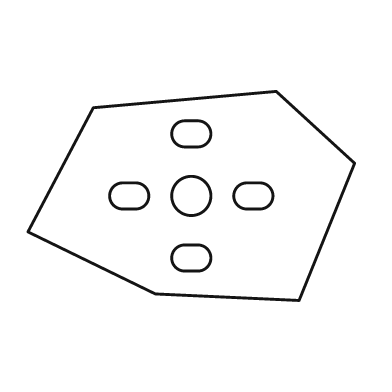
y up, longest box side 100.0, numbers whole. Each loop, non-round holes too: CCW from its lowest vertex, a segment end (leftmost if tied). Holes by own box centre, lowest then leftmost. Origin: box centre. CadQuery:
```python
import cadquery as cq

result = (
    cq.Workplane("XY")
    .moveTo(33.0, -32.0)
    .lineTo(50.0, 10.0)
    .lineTo(26.0, 32.0)
    .lineTo(-30.0, 27.0)
    .lineTo(-50.0, -11.0)
    .lineTo(-11.0, -30.0)
    .close()
    .moveTo(-2.0, -23.0)
    .lineTo(2.0, -23.0)
    .threePointArc((6.0, -19.0), (2.0, -15.0))
    .lineTo(-2.0, -15.0)
    .threePointArc((-6.0, -19.0), (-2.0, -23.0))
    .close()
    .moveTo(-21.0, -4.0)
    .lineTo(-17.0, -4.0)
    .threePointArc((-13.0, 0.0), (-17.0, 4.0))
    .lineTo(-21.0, 4.0)
    .threePointArc((-25.0, 0.0), (-21.0, -4.0))
    .close()
    .moveTo(0.0, 0.0)
    .circle(6.0)
    .moveTo(17.0, -4.0)
    .lineTo(21.0, -4.0)
    .threePointArc((25.0, 0.0), (21.0, 4.0))
    .lineTo(17.0, 4.0)
    .threePointArc((13.0, 0.0), (17.0, -4.0))
    .close()
    .moveTo(-2.0, 15.0)
    .lineTo(2.0, 15.0)
    .threePointArc((6.0, 19.0), (2.0, 23.0))
    .lineTo(-2.0, 23.0)
    .threePointArc((-6.0, 19.0), (-2.0, 15.0))
    .close()
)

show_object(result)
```